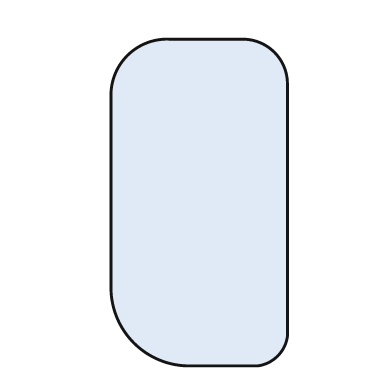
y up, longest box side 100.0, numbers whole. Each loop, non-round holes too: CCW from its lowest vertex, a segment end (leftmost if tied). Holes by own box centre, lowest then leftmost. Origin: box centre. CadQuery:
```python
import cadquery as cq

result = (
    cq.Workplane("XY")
    .moveTo(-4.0, -50.0)
    .lineTo(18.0, -50.0)
    .threePointArc((24.0, -47.0), (27.0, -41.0))
    .lineTo(27.0, 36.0)
    .threePointArc((23.0, 46.0), (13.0, 50.0))
    .lineTo(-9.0, 50.0)
    .threePointArc((-22.0, 45.0), (-27.0, 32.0))
    .lineTo(-27.0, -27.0)
    .threePointArc((-20.0, -43.0), (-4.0, -50.0))
    .close()
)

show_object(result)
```